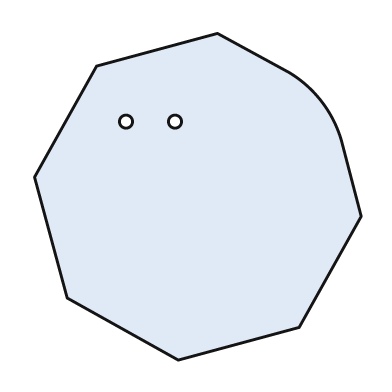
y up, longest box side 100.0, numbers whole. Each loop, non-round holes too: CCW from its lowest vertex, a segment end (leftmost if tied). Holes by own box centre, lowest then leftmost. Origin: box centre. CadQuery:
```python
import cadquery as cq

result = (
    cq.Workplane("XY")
    .moveTo(-6.0, -50.0)
    .lineTo(31.0, -40.0)
    .lineTo(50.0, -6.0)
    .lineTo(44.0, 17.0)
    .threePointArc((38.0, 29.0), (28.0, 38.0))
    .lineTo(6.0, 50.0)
    .lineTo(-31.0, 40.0)
    .lineTo(-50.0, 6.0)
    .lineTo(-40.0, -31.0)
    .close()
    .moveTo(-22.0, 23.0)
    .circle(2.0)
    .moveTo(-7.0, 23.0)
    .circle(2.0)
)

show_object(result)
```